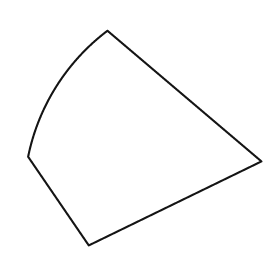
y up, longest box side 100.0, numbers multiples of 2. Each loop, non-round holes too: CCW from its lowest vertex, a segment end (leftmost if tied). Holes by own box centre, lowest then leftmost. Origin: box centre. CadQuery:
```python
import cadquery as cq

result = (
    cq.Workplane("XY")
    .moveTo(-24.0, -46.0)
    .lineTo(50.0, -10.0)
    .lineTo(-16.0, 46.0)
    .threePointArc((-38.0, 22.0), (-50.0, -8.0))
    .close()
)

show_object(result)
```